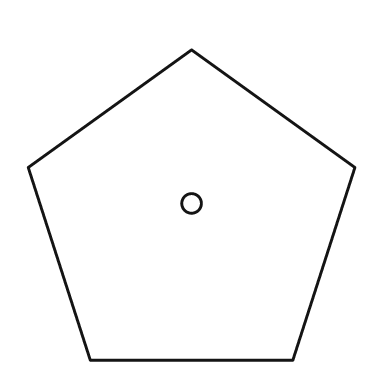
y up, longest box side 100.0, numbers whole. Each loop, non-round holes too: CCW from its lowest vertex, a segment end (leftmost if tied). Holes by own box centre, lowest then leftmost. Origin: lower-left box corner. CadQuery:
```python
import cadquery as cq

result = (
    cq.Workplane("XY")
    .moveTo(19.0, 0.0)
    .lineTo(81.0, 0.0)
    .lineTo(100.0, 59.0)
    .lineTo(50.0, 95.0)
    .lineTo(0.0, 59.0)
    .close()
    .moveTo(50.0, 48.0)
    .circle(3.0)
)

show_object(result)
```